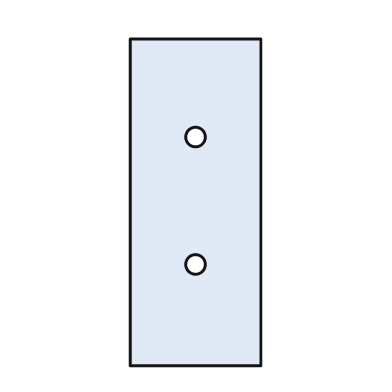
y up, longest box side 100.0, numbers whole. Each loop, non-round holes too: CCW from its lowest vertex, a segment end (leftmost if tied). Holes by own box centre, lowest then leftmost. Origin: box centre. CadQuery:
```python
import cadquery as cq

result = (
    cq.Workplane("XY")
    .moveTo(-20.0, -50.0)
    .lineTo(20.0, -50.0)
    .lineTo(20.0, 50.0)
    .lineTo(-20.0, 50.0)
    .close()
    .moveTo(0.0, -19.0)
    .circle(3.0)
    .moveTo(0.0, 20.0)
    .circle(3.0)
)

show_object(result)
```